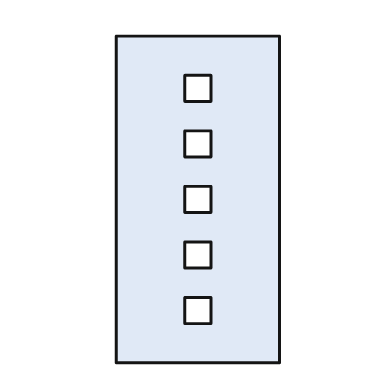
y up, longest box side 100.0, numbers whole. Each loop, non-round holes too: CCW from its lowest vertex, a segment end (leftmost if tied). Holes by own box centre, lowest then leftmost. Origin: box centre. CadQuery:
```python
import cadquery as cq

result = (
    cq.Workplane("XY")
    .moveTo(-25.0, -50.0)
    .lineTo(25.0, -50.0)
    .lineTo(25.0, 50.0)
    .lineTo(-25.0, 50.0)
    .close()
    .moveTo(-4.0, -38.0)
    .lineTo(4.0, -38.0)
    .lineTo(4.0, -30.0)
    .lineTo(-4.0, -30.0)
    .close()
    .moveTo(-4.0, -21.0)
    .lineTo(4.0, -21.0)
    .lineTo(4.0, -13.0)
    .lineTo(-4.0, -13.0)
    .close()
    .moveTo(-4.0, -4.0)
    .lineTo(4.0, -4.0)
    .lineTo(4.0, 4.0)
    .lineTo(-4.0, 4.0)
    .close()
    .moveTo(-4.0, 13.0)
    .lineTo(4.0, 13.0)
    .lineTo(4.0, 21.0)
    .lineTo(-4.0, 21.0)
    .close()
    .moveTo(-4.0, 30.0)
    .lineTo(4.0, 30.0)
    .lineTo(4.0, 38.0)
    .lineTo(-4.0, 38.0)
    .close()
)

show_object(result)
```